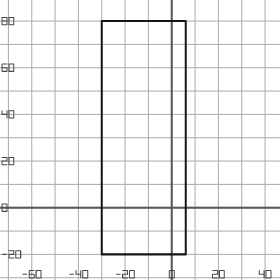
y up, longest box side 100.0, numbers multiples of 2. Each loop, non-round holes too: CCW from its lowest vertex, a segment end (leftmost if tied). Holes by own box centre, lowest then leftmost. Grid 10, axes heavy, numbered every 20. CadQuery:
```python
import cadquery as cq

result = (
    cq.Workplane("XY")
    .moveTo(-30.0, -20.0)
    .lineTo(6.0, -20.0)
    .lineTo(6.0, 80.0)
    .lineTo(-30.0, 80.0)
    .close()
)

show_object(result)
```